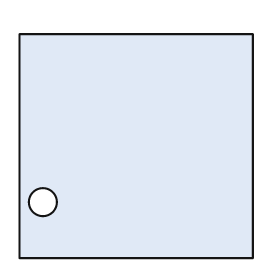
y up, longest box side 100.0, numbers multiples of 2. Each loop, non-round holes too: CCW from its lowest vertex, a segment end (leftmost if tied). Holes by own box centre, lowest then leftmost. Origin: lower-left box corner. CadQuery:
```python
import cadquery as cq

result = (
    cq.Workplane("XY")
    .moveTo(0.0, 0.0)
    .lineTo(100.0, 0.0)
    .lineTo(100.0, 96.0)
    .lineTo(0.0, 96.0)
    .close()
    .moveTo(10.0, 24.0)
    .circle(6.0)
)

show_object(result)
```